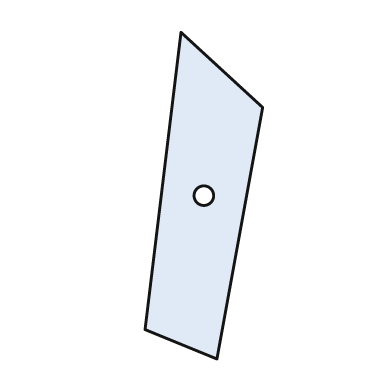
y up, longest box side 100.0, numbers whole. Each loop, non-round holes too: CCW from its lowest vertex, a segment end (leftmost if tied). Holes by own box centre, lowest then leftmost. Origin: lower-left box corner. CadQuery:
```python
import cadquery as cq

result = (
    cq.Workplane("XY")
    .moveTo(22.0, 0.0)
    .lineTo(36.0, 77.0)
    .lineTo(11.0, 100.0)
    .lineTo(0.0, 9.0)
    .close()
    .moveTo(18.0, 50.0)
    .circle(3.0)
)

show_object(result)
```